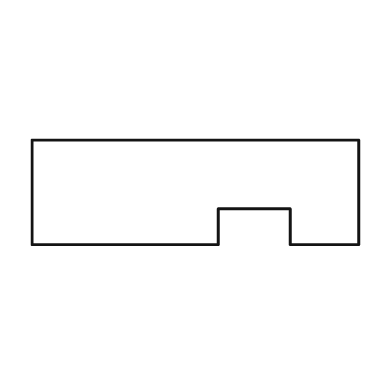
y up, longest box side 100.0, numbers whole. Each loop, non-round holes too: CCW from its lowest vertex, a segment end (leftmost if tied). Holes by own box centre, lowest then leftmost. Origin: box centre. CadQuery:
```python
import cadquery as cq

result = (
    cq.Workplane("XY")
    .moveTo(-50.0, -16.0)
    .lineTo(7.0, -16.0)
    .lineTo(7.0, -5.0)
    .lineTo(29.0, -5.0)
    .lineTo(29.0, -16.0)
    .lineTo(50.0, -16.0)
    .lineTo(50.0, 16.0)
    .lineTo(-50.0, 16.0)
    .close()
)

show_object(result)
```